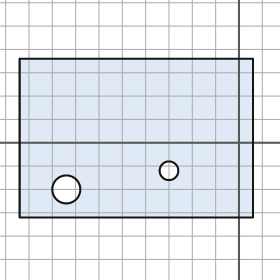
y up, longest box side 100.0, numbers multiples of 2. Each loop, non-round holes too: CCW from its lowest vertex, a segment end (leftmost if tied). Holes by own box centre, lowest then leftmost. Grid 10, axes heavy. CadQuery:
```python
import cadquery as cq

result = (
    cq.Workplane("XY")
    .moveTo(-94.0, -32.0)
    .lineTo(6.0, -32.0)
    .lineTo(6.0, 36.0)
    .lineTo(-94.0, 36.0)
    .close()
    .moveTo(-74.0, -20.0)
    .circle(6.0)
    .moveTo(-30.0, -12.0)
    .circle(4.0)
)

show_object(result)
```